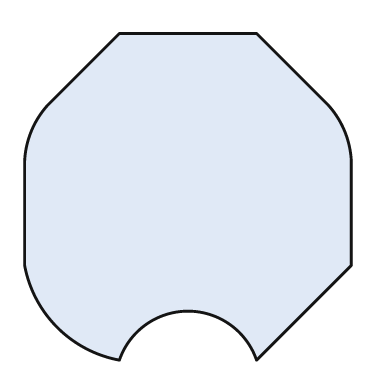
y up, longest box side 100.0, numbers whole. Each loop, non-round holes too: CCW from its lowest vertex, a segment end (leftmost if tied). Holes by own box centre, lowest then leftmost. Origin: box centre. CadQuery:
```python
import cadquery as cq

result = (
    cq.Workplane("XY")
    .moveTo(-21.0, -50.0)
    .threePointArc((0.0, -35.0), (21.0, -50.0))
    .lineTo(50.0, -21.0)
    .lineTo(50.0, 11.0)
    .threePointArc((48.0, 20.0), (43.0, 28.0))
    .lineTo(21.0, 50.0)
    .lineTo(-21.0, 50.0)
    .lineTo(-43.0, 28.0)
    .threePointArc((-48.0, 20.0), (-50.0, 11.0))
    .lineTo(-50.0, -21.0)
    .threePointArc((-40.0, -40.0), (-21.0, -50.0))
    .close()
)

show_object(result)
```